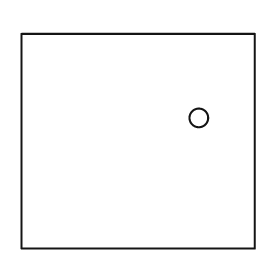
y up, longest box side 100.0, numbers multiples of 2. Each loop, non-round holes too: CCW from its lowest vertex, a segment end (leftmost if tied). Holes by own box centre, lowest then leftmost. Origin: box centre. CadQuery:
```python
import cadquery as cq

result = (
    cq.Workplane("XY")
    .moveTo(-50.0, -46.0)
    .lineTo(50.0, -46.0)
    .lineTo(50.0, 46.0)
    .lineTo(-50.0, 46.0)
    .close()
    .moveTo(26.0, 10.0)
    .circle(4.0)
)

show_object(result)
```